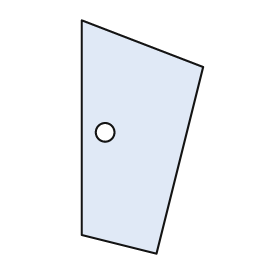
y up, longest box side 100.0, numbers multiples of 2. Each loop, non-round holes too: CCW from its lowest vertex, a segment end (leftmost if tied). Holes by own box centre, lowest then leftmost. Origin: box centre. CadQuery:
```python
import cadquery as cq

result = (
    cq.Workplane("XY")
    .moveTo(6.0, -50.0)
    .lineTo(26.0, 30.0)
    .lineTo(-26.0, 50.0)
    .lineTo(-26.0, -42.0)
    .close()
    .moveTo(-16.0, 2.0)
    .circle(4.0)
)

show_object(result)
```